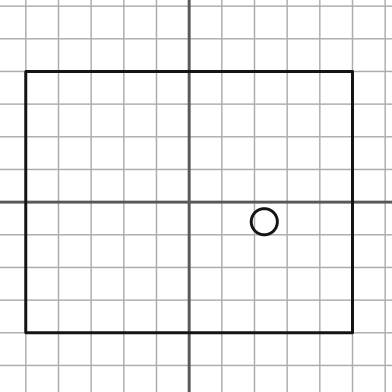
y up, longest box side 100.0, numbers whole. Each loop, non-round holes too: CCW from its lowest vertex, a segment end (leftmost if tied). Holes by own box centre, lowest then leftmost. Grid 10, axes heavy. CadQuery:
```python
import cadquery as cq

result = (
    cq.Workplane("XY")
    .moveTo(-50.0, -40.0)
    .lineTo(50.0, -40.0)
    .lineTo(50.0, 40.0)
    .lineTo(-50.0, 40.0)
    .close()
    .moveTo(23.0, -6.0)
    .circle(4.0)
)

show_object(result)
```